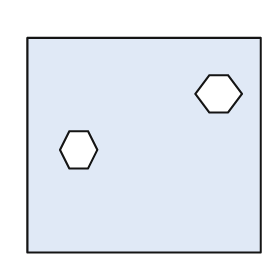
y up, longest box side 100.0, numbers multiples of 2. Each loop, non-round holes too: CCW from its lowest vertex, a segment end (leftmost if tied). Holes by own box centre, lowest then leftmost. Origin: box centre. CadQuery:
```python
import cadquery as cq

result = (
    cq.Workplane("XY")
    .moveTo(-50.0, -46.0)
    .lineTo(50.0, -46.0)
    .lineTo(50.0, 46.0)
    .lineTo(-50.0, 46.0)
    .close()
    .moveTo(-32.0, -10.0)
    .lineTo(-24.0, -10.0)
    .lineTo(-20.0, -2.0)
    .lineTo(-24.0, 6.0)
    .lineTo(-32.0, 6.0)
    .lineTo(-36.0, -2.0)
    .close()
    .moveTo(28.0, 14.0)
    .lineTo(36.0, 14.0)
    .lineTo(42.0, 22.0)
    .lineTo(36.0, 30.0)
    .lineTo(28.0, 30.0)
    .lineTo(22.0, 22.0)
    .close()
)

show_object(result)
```